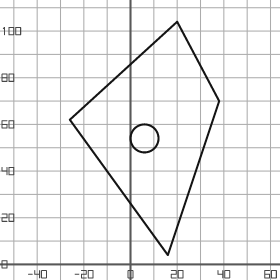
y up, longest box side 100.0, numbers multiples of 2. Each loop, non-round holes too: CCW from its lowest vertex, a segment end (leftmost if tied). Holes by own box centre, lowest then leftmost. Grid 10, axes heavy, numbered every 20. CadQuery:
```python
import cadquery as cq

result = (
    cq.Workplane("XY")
    .moveTo(16.0, 4.0)
    .lineTo(38.0, 70.0)
    .lineTo(20.0, 104.0)
    .lineTo(-26.0, 62.0)
    .close()
    .moveTo(6.0, 54.0)
    .circle(6.0)
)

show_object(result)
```